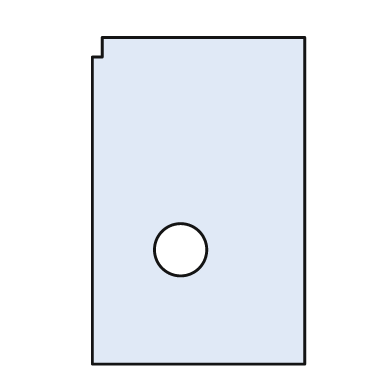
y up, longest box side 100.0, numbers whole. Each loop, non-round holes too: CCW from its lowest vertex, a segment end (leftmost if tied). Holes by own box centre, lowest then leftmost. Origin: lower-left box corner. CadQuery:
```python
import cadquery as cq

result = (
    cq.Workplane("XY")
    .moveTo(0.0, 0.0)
    .lineTo(65.0, 0.0)
    .lineTo(65.0, 100.0)
    .lineTo(3.0, 100.0)
    .lineTo(3.0, 94.0)
    .lineTo(0.0, 94.0)
    .close()
    .moveTo(27.0, 35.0)
    .circle(8.0)
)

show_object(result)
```